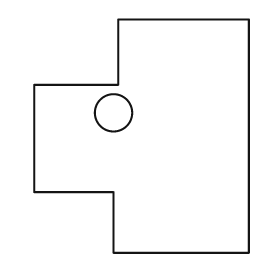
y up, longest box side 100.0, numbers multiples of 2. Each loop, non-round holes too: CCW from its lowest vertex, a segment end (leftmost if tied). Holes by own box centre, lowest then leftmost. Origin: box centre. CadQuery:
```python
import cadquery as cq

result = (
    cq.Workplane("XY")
    .moveTo(-12.0, -50.0)
    .lineTo(46.0, -50.0)
    .lineTo(46.0, 50.0)
    .lineTo(-10.0, 50.0)
    .lineTo(-10.0, 22.0)
    .lineTo(-46.0, 22.0)
    .lineTo(-46.0, -24.0)
    .lineTo(-12.0, -24.0)
    .close()
    .moveTo(-12.0, 10.0)
    .circle(8.0)
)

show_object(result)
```